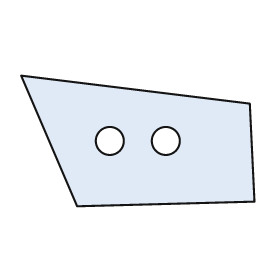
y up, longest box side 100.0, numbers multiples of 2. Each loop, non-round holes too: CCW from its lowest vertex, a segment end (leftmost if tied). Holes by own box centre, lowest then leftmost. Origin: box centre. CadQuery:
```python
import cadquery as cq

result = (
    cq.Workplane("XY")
    .moveTo(-26.0, -28.0)
    .lineTo(50.0, -26.0)
    .lineTo(48.0, 16.0)
    .lineTo(-50.0, 28.0)
    .close()
    .moveTo(-12.0, 0.0)
    .circle(6.0)
    .moveTo(12.0, 0.0)
    .circle(6.0)
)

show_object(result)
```